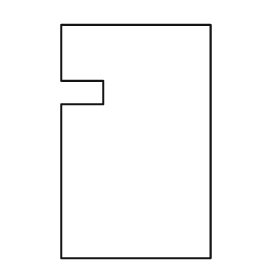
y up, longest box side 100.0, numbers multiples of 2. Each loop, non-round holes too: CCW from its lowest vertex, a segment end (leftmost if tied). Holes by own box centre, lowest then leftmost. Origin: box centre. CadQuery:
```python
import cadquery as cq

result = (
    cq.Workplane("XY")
    .moveTo(-32.0, -50.0)
    .lineTo(32.0, -50.0)
    .lineTo(32.0, 50.0)
    .lineTo(-32.0, 50.0)
    .lineTo(-32.0, 26.0)
    .lineTo(-14.0, 26.0)
    .lineTo(-14.0, 16.0)
    .lineTo(-32.0, 16.0)
    .close()
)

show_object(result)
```